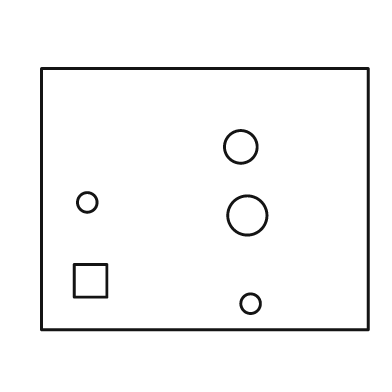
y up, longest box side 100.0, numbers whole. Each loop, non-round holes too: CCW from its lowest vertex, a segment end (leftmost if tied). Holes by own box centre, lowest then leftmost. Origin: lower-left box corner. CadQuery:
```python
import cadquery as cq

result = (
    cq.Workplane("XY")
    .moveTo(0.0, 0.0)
    .lineTo(100.0, 0.0)
    .lineTo(100.0, 80.0)
    .lineTo(0.0, 80.0)
    .close()
    .moveTo(64.0, 8.0)
    .circle(3.0)
    .moveTo(10.0, 10.0)
    .lineTo(20.0, 10.0)
    .lineTo(20.0, 20.0)
    .lineTo(10.0, 20.0)
    .close()
    .moveTo(63.0, 35.0)
    .circle(6.0)
    .moveTo(14.0, 39.0)
    .circle(3.0)
    .moveTo(61.0, 56.0)
    .circle(5.0)
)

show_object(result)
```